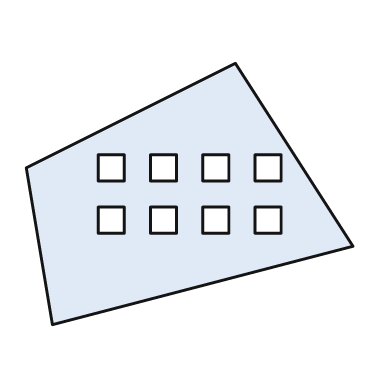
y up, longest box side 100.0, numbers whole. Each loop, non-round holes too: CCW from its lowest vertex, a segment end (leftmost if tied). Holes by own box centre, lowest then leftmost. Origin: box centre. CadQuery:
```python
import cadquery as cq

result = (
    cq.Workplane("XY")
    .moveTo(-42.0, -40.0)
    .lineTo(50.0, -16.0)
    .lineTo(14.0, 40.0)
    .lineTo(-50.0, 8.0)
    .close()
    .moveTo(-28.0, -12.0)
    .lineTo(-20.0, -12.0)
    .lineTo(-20.0, -4.0)
    .lineTo(-28.0, -4.0)
    .close()
    .moveTo(-12.0, -12.0)
    .lineTo(-4.0, -12.0)
    .lineTo(-4.0, -4.0)
    .lineTo(-12.0, -4.0)
    .close()
    .moveTo(4.0, -12.0)
    .lineTo(12.0, -12.0)
    .lineTo(12.0, -4.0)
    .lineTo(4.0, -4.0)
    .close()
    .moveTo(20.0, -12.0)
    .lineTo(28.0, -12.0)
    .lineTo(28.0, -4.0)
    .lineTo(20.0, -4.0)
    .close()
    .moveTo(-28.0, 4.0)
    .lineTo(-20.0, 4.0)
    .lineTo(-20.0, 12.0)
    .lineTo(-28.0, 12.0)
    .close()
    .moveTo(-12.0, 4.0)
    .lineTo(-4.0, 4.0)
    .lineTo(-4.0, 12.0)
    .lineTo(-12.0, 12.0)
    .close()
    .moveTo(4.0, 4.0)
    .lineTo(12.0, 4.0)
    .lineTo(12.0, 12.0)
    .lineTo(4.0, 12.0)
    .close()
    .moveTo(20.0, 4.0)
    .lineTo(28.0, 4.0)
    .lineTo(28.0, 12.0)
    .lineTo(20.0, 12.0)
    .close()
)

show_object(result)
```